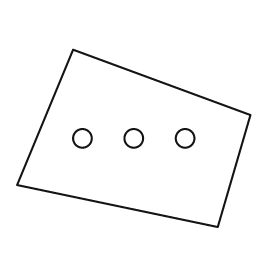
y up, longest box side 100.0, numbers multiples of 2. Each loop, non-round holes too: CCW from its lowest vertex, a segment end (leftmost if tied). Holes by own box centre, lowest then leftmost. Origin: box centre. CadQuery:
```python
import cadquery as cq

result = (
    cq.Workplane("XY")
    .moveTo(36.0, -38.0)
    .lineTo(50.0, 10.0)
    .lineTo(-26.0, 38.0)
    .lineTo(-50.0, -20.0)
    .close()
    .moveTo(-22.0, 0.0)
    .circle(4.0)
    .moveTo(0.0, 0.0)
    .circle(4.0)
    .moveTo(22.0, 0.0)
    .circle(4.0)
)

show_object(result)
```